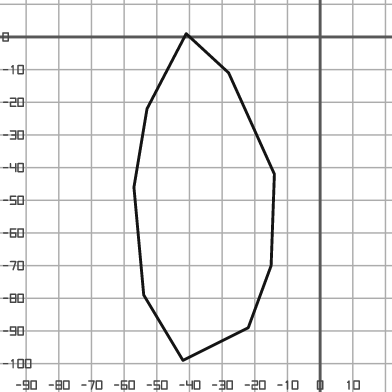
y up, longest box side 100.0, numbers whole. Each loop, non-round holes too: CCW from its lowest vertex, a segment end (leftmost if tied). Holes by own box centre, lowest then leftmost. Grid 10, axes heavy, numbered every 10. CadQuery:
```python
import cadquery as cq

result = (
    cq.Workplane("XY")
    .moveTo(-42.0, -99.0)
    .lineTo(-22.0, -89.0)
    .lineTo(-15.0, -70.0)
    .lineTo(-14.0, -42.0)
    .lineTo(-28.0, -11.0)
    .lineTo(-41.0, 1.0)
    .lineTo(-53.0, -22.0)
    .lineTo(-57.0, -46.0)
    .lineTo(-54.0, -79.0)
    .close()
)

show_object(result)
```